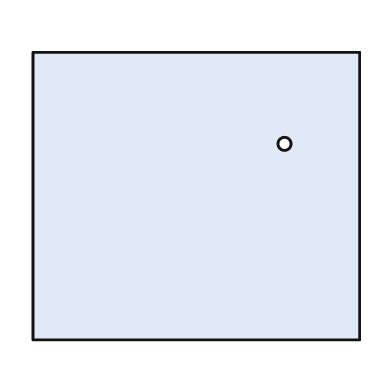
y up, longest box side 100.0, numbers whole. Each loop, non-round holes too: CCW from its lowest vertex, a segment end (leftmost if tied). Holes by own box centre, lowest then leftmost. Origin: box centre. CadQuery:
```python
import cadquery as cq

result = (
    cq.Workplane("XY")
    .moveTo(-50.0, -44.0)
    .lineTo(50.0, -44.0)
    .lineTo(50.0, 44.0)
    .lineTo(-50.0, 44.0)
    .close()
    .moveTo(27.0, 16.0)
    .circle(2.0)
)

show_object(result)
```